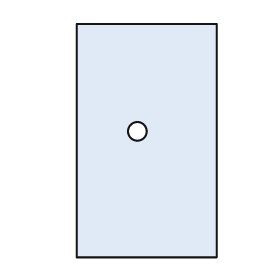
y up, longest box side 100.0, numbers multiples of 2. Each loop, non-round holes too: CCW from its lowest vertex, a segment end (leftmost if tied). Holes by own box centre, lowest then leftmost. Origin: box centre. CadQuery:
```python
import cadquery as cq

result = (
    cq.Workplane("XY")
    .moveTo(-30.0, -50.0)
    .lineTo(30.0, -50.0)
    .lineTo(30.0, 50.0)
    .lineTo(-30.0, 50.0)
    .close()
    .moveTo(-4.0, 4.0)
    .circle(4.0)
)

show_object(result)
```